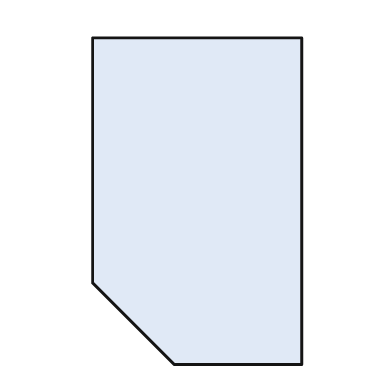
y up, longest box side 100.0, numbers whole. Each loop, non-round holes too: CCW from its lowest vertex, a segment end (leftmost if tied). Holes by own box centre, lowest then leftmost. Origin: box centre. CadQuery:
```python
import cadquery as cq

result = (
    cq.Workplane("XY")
    .moveTo(-7.0, -50.0)
    .lineTo(32.0, -50.0)
    .lineTo(32.0, 50.0)
    .lineTo(-32.0, 50.0)
    .lineTo(-32.0, -25.0)
    .close()
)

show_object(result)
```